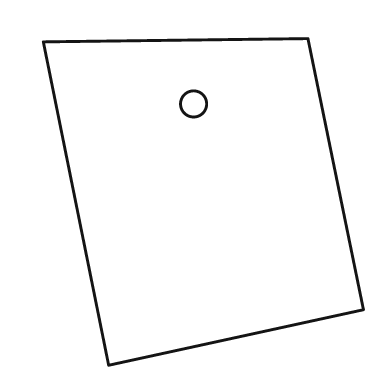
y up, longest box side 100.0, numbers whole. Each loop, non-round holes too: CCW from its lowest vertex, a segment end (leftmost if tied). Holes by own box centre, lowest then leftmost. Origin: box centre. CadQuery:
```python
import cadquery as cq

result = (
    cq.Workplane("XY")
    .moveTo(-29.0, -50.0)
    .lineTo(49.0, -33.0)
    .lineTo(32.0, 50.0)
    .lineTo(-49.0, 49.0)
    .close()
    .moveTo(-3.0, 30.0)
    .circle(4.0)
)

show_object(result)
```